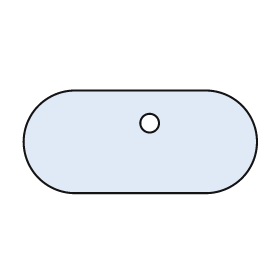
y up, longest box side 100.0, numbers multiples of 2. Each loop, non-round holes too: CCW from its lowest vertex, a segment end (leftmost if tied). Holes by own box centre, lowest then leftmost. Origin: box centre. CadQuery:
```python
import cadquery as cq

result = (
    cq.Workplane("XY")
    .moveTo(-28.0, -22.0)
    .lineTo(28.0, -22.0)
    .threePointArc((50.0, 0.0), (28.0, 22.0))
    .lineTo(-28.0, 22.0)
    .threePointArc((-50.0, 0.0), (-28.0, -22.0))
    .close()
    .moveTo(4.0, 8.0)
    .circle(4.0)
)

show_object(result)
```